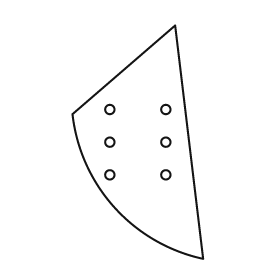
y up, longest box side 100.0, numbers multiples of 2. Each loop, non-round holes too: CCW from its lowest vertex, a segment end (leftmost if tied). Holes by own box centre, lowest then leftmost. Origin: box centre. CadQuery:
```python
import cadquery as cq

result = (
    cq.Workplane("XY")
    .moveTo(28.0, -50.0)
    .lineTo(16.0, 50.0)
    .lineTo(-28.0, 12.0)
    .threePointArc((-10.0, -28.0), (28.0, -50.0))
    .close()
    .moveTo(-12.0, -14.0)
    .circle(2.0)
    .moveTo(12.0, -14.0)
    .circle(2.0)
    .moveTo(-12.0, 0.0)
    .circle(2.0)
    .moveTo(12.0, 0.0)
    .circle(2.0)
    .moveTo(-12.0, 14.0)
    .circle(2.0)
    .moveTo(12.0, 14.0)
    .circle(2.0)
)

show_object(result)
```